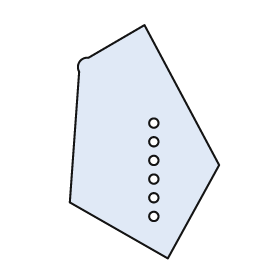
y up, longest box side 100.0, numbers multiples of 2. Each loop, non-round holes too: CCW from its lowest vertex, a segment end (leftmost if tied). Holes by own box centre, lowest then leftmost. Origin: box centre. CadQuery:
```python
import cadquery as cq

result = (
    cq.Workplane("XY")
    .moveTo(10.0, -50.0)
    .lineTo(32.0, -10.0)
    .lineTo(0.0, 50.0)
    .lineTo(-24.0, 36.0)
    .threePointArc((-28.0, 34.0), (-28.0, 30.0))
    .lineTo(-32.0, -26.0)
    .close()
    .moveTo(4.0, -32.0)
    .circle(2.0)
    .moveTo(4.0, -24.0)
    .circle(2.0)
    .moveTo(4.0, -16.0)
    .circle(2.0)
    .moveTo(4.0, -8.0)
    .circle(2.0)
    .moveTo(4.0, 0.0)
    .circle(2.0)
    .moveTo(4.0, 8.0)
    .circle(2.0)
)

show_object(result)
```